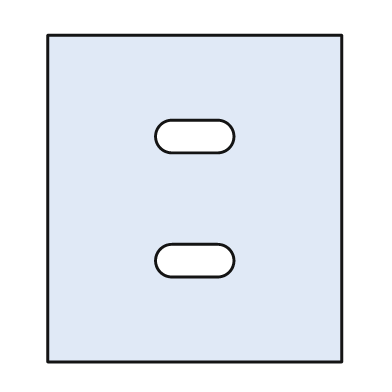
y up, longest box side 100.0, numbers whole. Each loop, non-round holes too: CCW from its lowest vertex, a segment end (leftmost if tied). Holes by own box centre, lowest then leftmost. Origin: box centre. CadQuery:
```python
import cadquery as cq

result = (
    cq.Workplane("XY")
    .moveTo(-45.0, -50.0)
    .lineTo(45.0, -50.0)
    .lineTo(45.0, 50.0)
    .lineTo(-45.0, 50.0)
    .close()
    .moveTo(-7.0, -24.0)
    .lineTo(7.0, -24.0)
    .threePointArc((12.0, -19.0), (7.0, -14.0))
    .lineTo(-7.0, -14.0)
    .threePointArc((-12.0, -19.0), (-7.0, -24.0))
    .close()
    .moveTo(-7.0, 14.0)
    .lineTo(7.0, 14.0)
    .threePointArc((12.0, 19.0), (7.0, 24.0))
    .lineTo(-7.0, 24.0)
    .threePointArc((-12.0, 19.0), (-7.0, 14.0))
    .close()
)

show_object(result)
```